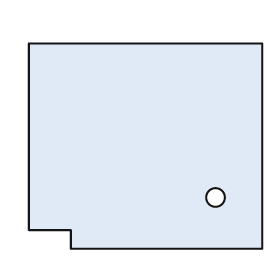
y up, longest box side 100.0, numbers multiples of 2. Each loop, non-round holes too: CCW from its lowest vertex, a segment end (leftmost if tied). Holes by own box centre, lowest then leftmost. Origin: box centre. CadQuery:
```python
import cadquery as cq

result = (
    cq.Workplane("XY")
    .moveTo(-32.0, -44.0)
    .lineTo(50.0, -44.0)
    .lineTo(50.0, 44.0)
    .lineTo(-50.0, 44.0)
    .lineTo(-50.0, -36.0)
    .lineTo(-32.0, -36.0)
    .close()
    .moveTo(30.0, -22.0)
    .circle(4.0)
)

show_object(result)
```